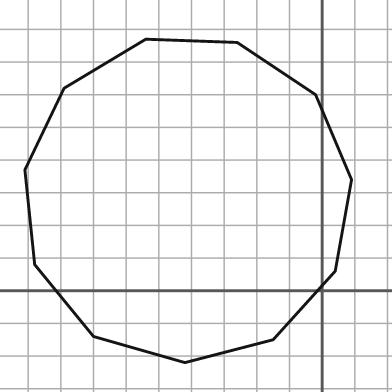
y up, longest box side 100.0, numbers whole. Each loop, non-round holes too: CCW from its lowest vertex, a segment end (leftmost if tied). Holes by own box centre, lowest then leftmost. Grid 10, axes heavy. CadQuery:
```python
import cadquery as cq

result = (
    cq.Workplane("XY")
    .moveTo(-42.0, -22.0)
    .lineTo(-15.0, -15.0)
    .lineTo(4.0, 6.0)
    .lineTo(9.0, 34.0)
    .lineTo(-2.0, 60.0)
    .lineTo(-26.0, 76.0)
    .lineTo(-54.0, 77.0)
    .lineTo(-79.0, 62.0)
    .lineTo(-91.0, 37.0)
    .lineTo(-88.0, 8.0)
    .lineTo(-70.0, -14.0)
    .close()
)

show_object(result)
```